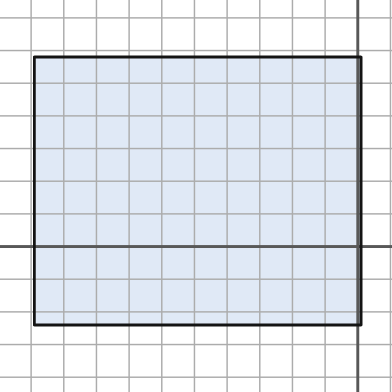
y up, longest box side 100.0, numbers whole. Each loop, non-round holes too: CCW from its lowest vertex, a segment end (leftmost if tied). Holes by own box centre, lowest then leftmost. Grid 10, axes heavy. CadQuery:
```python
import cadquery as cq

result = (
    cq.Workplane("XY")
    .moveTo(-99.0, -24.0)
    .lineTo(1.0, -24.0)
    .lineTo(1.0, 58.0)
    .lineTo(-99.0, 58.0)
    .close()
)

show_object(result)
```